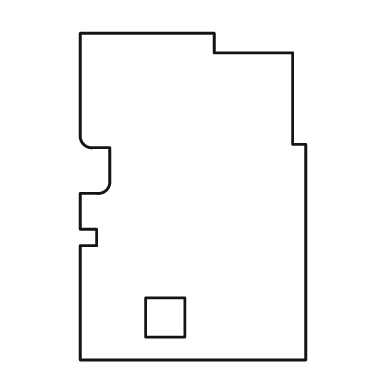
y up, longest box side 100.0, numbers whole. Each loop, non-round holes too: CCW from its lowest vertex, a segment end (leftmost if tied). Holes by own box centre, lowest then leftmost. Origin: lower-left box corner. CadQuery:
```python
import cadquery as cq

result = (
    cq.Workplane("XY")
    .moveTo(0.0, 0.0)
    .lineTo(69.0, 0.0)
    .lineTo(69.0, 66.0)
    .lineTo(65.0, 66.0)
    .lineTo(65.0, 94.0)
    .lineTo(41.0, 94.0)
    .lineTo(41.0, 100.0)
    .lineTo(0.0, 100.0)
    .lineTo(0.0, 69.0)
    .threePointArc((1.0, 66.0), (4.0, 65.0))
    .lineTo(9.0, 65.0)
    .lineTo(9.0, 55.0)
    .threePointArc((8.0, 52.0), (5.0, 51.0))
    .lineTo(0.0, 51.0)
    .lineTo(0.0, 40.0)
    .lineTo(5.0, 40.0)
    .lineTo(5.0, 35.0)
    .lineTo(0.0, 35.0)
    .close()
    .moveTo(20.0, 7.0)
    .lineTo(32.0, 7.0)
    .lineTo(32.0, 19.0)
    .lineTo(20.0, 19.0)
    .close()
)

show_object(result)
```